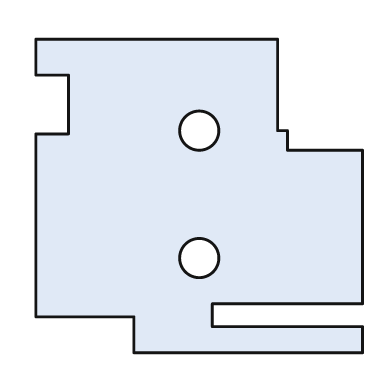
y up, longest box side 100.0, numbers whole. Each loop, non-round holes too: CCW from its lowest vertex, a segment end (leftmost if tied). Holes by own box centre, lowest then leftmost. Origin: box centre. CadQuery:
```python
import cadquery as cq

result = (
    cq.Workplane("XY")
    .moveTo(-20.0, -48.0)
    .lineTo(50.0, -48.0)
    .lineTo(50.0, -40.0)
    .lineTo(4.0, -40.0)
    .lineTo(4.0, -33.0)
    .lineTo(50.0, -33.0)
    .lineTo(50.0, 14.0)
    .lineTo(27.0, 14.0)
    .lineTo(27.0, 20.0)
    .lineTo(24.0, 20.0)
    .lineTo(24.0, 48.0)
    .lineTo(-50.0, 48.0)
    .lineTo(-50.0, 37.0)
    .lineTo(-40.0, 37.0)
    .lineTo(-40.0, 19.0)
    .lineTo(-50.0, 19.0)
    .lineTo(-50.0, -37.0)
    .lineTo(-20.0, -37.0)
    .close()
    .moveTo(0.0, -19.0)
    .circle(6.0)
    .moveTo(0.0, 20.0)
    .circle(6.0)
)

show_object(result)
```